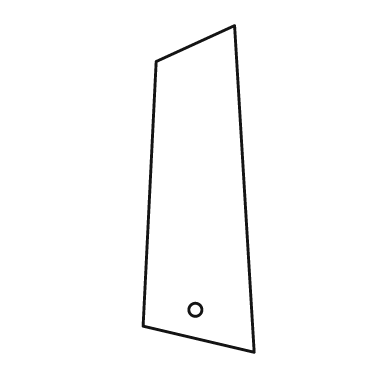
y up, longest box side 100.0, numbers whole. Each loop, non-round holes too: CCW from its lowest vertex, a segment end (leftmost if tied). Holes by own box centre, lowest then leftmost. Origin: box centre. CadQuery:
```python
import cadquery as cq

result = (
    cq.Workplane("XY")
    .moveTo(17.0, -50.0)
    .lineTo(11.0, 50.0)
    .lineTo(-13.0, 39.0)
    .lineTo(-17.0, -42.0)
    .close()
    .moveTo(-1.0, -37.0)
    .circle(2.0)
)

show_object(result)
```